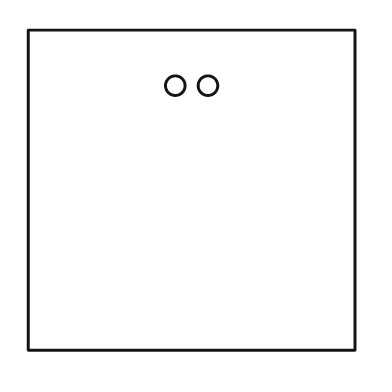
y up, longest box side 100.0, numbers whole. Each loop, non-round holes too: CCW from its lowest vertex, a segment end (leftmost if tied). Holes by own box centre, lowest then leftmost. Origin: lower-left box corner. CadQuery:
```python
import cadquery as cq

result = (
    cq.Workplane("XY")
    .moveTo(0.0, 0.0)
    .lineTo(100.0, 0.0)
    .lineTo(100.0, 98.0)
    .lineTo(0.0, 98.0)
    .close()
    .moveTo(45.0, 81.0)
    .circle(3.0)
    .moveTo(55.0, 81.0)
    .circle(3.0)
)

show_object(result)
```